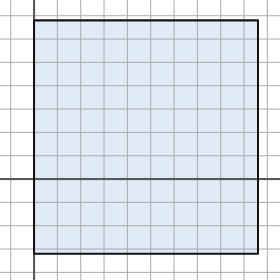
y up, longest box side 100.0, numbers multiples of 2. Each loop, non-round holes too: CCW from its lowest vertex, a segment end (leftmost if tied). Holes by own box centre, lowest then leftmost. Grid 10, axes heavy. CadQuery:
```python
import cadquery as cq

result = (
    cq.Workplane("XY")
    .moveTo(0.0, -32.0)
    .lineTo(96.0, -32.0)
    .lineTo(96.0, 68.0)
    .lineTo(0.0, 68.0)
    .close()
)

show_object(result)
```